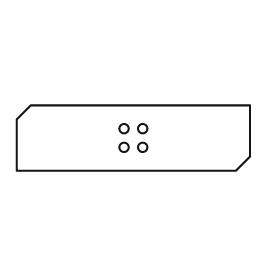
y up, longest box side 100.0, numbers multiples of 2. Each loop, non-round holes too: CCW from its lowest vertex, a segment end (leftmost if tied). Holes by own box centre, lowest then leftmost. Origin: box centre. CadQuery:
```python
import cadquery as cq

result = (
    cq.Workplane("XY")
    .moveTo(-50.0, -14.0)
    .lineTo(44.0, -14.0)
    .lineTo(50.0, -8.0)
    .lineTo(50.0, 14.0)
    .lineTo(-44.0, 14.0)
    .lineTo(-50.0, 8.0)
    .close()
    .moveTo(-4.0, -4.0)
    .circle(2.0)
    .moveTo(4.0, -4.0)
    .circle(2.0)
    .moveTo(-4.0, 4.0)
    .circle(2.0)
    .moveTo(4.0, 4.0)
    .circle(2.0)
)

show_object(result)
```